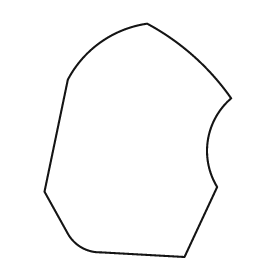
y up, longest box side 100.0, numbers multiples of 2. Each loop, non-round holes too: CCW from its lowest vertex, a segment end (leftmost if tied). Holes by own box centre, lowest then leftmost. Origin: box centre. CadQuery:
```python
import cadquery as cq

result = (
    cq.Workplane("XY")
    .moveTo(20.0, -50.0)
    .lineTo(34.0, -20.0)
    .threePointArc((30.0, 0.0), (40.0, 18.0))
    .threePointArc((24.0, 36.0), (4.0, 50.0))
    .threePointArc((-16.0, 42.0), (-30.0, 26.0))
    .lineTo(-40.0, -22.0)
    .lineTo(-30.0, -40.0)
    .threePointArc((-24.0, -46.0), (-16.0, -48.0))
    .close()
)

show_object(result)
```